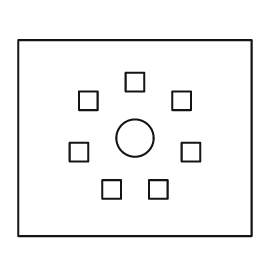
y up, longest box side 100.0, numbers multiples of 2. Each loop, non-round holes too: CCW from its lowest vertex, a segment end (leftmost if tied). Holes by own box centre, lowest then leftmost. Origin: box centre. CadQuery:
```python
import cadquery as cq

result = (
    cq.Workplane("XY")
    .moveTo(-50.0, -42.0)
    .lineTo(50.0, -42.0)
    .lineTo(50.0, 42.0)
    .lineTo(-50.0, 42.0)
    .close()
    .moveTo(-14.0, -26.0)
    .lineTo(-6.0, -26.0)
    .lineTo(-6.0, -18.0)
    .lineTo(-14.0, -18.0)
    .close()
    .moveTo(6.0, -26.0)
    .lineTo(14.0, -26.0)
    .lineTo(14.0, -18.0)
    .lineTo(6.0, -18.0)
    .close()
    .moveTo(-28.0, -10.0)
    .lineTo(-20.0, -10.0)
    .lineTo(-20.0, -2.0)
    .lineTo(-28.0, -2.0)
    .close()
    .moveTo(20.0, -10.0)
    .lineTo(28.0, -10.0)
    .lineTo(28.0, -2.0)
    .lineTo(20.0, -2.0)
    .close()
    .moveTo(0.0, 0.0)
    .circle(8.0)
    .moveTo(-24.0, 12.0)
    .lineTo(-16.0, 12.0)
    .lineTo(-16.0, 20.0)
    .lineTo(-24.0, 20.0)
    .close()
    .moveTo(16.0, 12.0)
    .lineTo(24.0, 12.0)
    .lineTo(24.0, 20.0)
    .lineTo(16.0, 20.0)
    .close()
    .moveTo(-4.0, 20.0)
    .lineTo(4.0, 20.0)
    .lineTo(4.0, 28.0)
    .lineTo(-4.0, 28.0)
    .close()
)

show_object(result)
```